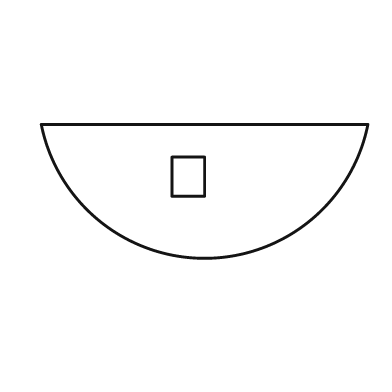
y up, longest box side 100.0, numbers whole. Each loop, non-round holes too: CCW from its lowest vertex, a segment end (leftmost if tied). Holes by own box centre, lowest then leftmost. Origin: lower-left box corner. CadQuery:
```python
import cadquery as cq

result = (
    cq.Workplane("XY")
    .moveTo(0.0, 41.0)
    .threePointArc((50.0, 0.0), (100.0, 41.0))
    .close()
    .moveTo(40.0, 19.0)
    .lineTo(50.0, 19.0)
    .lineTo(50.0, 31.0)
    .lineTo(40.0, 31.0)
    .close()
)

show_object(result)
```